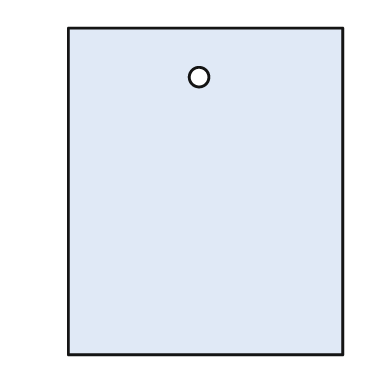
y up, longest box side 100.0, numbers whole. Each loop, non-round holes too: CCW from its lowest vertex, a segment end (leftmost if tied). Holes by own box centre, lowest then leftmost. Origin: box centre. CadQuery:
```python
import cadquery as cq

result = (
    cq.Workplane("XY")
    .moveTo(-42.0, -50.0)
    .lineTo(42.0, -50.0)
    .lineTo(42.0, 50.0)
    .lineTo(-42.0, 50.0)
    .close()
    .moveTo(-2.0, 35.0)
    .circle(3.0)
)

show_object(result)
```